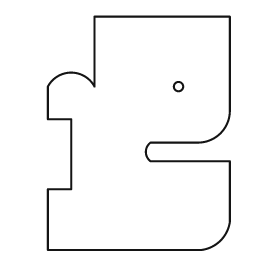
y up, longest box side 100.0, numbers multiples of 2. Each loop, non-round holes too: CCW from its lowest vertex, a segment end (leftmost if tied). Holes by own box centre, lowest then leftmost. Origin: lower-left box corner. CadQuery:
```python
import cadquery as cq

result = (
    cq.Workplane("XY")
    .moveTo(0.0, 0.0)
    .lineTo(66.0, 0.0)
    .threePointArc((74.0, 4.0), (78.0, 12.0))
    .lineTo(78.0, 38.0)
    .lineTo(44.0, 38.0)
    .threePointArc((42.0, 42.0), (44.0, 46.0))
    .lineTo(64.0, 46.0)
    .threePointArc((74.0, 50.0), (78.0, 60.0))
    .lineTo(78.0, 100.0)
    .lineTo(20.0, 100.0)
    .lineTo(20.0, 70.0)
    .threePointArc((10.0, 76.0), (0.0, 70.0))
    .lineTo(0.0, 56.0)
    .lineTo(10.0, 56.0)
    .lineTo(10.0, 26.0)
    .lineTo(0.0, 26.0)
    .close()
    .moveTo(56.0, 70.0)
    .circle(2.0)
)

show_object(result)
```